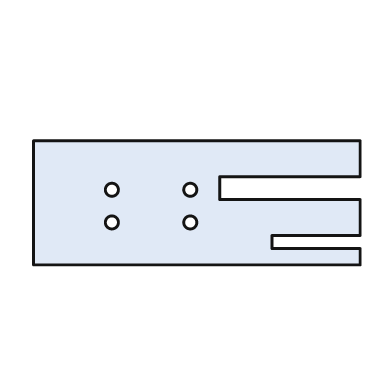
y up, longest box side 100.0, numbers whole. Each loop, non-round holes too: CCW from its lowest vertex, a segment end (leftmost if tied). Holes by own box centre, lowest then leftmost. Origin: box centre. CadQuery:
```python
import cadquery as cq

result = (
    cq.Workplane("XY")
    .moveTo(-50.0, -19.0)
    .lineTo(50.0, -19.0)
    .lineTo(50.0, -14.0)
    .lineTo(23.0, -14.0)
    .lineTo(23.0, -10.0)
    .lineTo(50.0, -10.0)
    .lineTo(50.0, 1.0)
    .lineTo(7.0, 1.0)
    .lineTo(7.0, 8.0)
    .lineTo(50.0, 8.0)
    .lineTo(50.0, 19.0)
    .lineTo(-50.0, 19.0)
    .close()
    .moveTo(-26.0, -6.0)
    .circle(2.0)
    .moveTo(-2.0, -6.0)
    .circle(2.0)
    .moveTo(-26.0, 4.0)
    .circle(2.0)
    .moveTo(-2.0, 4.0)
    .circle(2.0)
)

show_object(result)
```